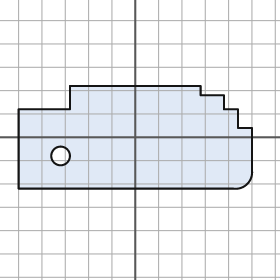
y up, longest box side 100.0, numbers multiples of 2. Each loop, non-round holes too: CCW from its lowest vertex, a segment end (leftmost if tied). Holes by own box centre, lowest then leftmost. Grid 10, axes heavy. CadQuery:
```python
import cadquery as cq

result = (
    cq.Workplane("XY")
    .moveTo(-50.0, -22.0)
    .lineTo(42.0, -22.0)
    .threePointArc((48.0, -20.0), (50.0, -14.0))
    .lineTo(50.0, 4.0)
    .lineTo(44.0, 4.0)
    .lineTo(44.0, 12.0)
    .lineTo(38.0, 12.0)
    .lineTo(38.0, 18.0)
    .lineTo(28.0, 18.0)
    .lineTo(28.0, 22.0)
    .lineTo(-28.0, 22.0)
    .lineTo(-28.0, 12.0)
    .lineTo(-50.0, 12.0)
    .close()
    .moveTo(-32.0, -8.0)
    .circle(4.0)
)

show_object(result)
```